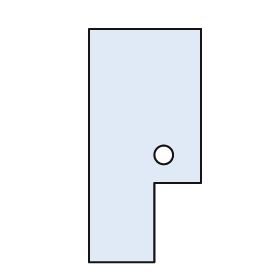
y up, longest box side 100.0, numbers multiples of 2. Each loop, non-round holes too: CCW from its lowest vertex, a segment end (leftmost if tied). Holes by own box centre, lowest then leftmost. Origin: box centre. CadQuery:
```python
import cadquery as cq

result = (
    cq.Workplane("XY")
    .moveTo(-24.0, -50.0)
    .lineTo(4.0, -50.0)
    .lineTo(4.0, -16.0)
    .lineTo(24.0, -16.0)
    .lineTo(24.0, 50.0)
    .lineTo(-24.0, 50.0)
    .close()
    .moveTo(8.0, -4.0)
    .circle(4.0)
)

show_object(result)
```